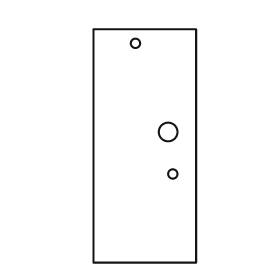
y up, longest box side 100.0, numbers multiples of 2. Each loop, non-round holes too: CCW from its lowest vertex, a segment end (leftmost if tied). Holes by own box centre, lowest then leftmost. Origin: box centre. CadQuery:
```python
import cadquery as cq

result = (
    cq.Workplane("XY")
    .moveTo(-22.0, -50.0)
    .lineTo(22.0, -50.0)
    .lineTo(22.0, 50.0)
    .lineTo(-22.0, 50.0)
    .close()
    .moveTo(12.0, -12.0)
    .circle(2.0)
    .moveTo(10.0, 6.0)
    .circle(4.0)
    .moveTo(-4.0, 44.0)
    .circle(2.0)
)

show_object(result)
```